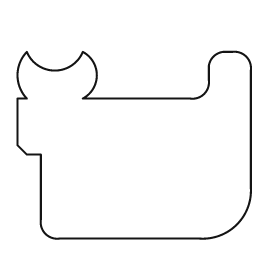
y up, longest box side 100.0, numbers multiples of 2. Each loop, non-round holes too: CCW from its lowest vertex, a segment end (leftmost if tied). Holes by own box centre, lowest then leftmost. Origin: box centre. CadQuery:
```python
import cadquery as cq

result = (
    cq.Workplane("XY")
    .moveTo(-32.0, -40.0)
    .lineTo(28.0, -40.0)
    .threePointArc((44.0, -34.0), (50.0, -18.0))
    .lineTo(50.0, 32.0)
    .threePointArc((48.0, 38.0), (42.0, 40.0))
    .lineTo(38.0, 40.0)
    .threePointArc((34.0, 38.0), (32.0, 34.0))
    .lineTo(32.0, 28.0)
    .threePointArc((30.0, 22.0), (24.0, 20.0))
    .lineTo(-22.0, 20.0)
    .threePointArc((-16.0, 30.0), (-22.0, 40.0))
    .threePointArc((-34.0, 32.0), (-46.0, 40.0))
    .threePointArc((-50.0, 30.0), (-46.0, 20.0))
    .lineTo(-50.0, 20.0)
    .lineTo(-50.0, 0.0)
    .lineTo(-46.0, -4.0)
    .lineTo(-40.0, -4.0)
    .lineTo(-40.0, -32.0)
    .threePointArc((-38.0, -38.0), (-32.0, -40.0))
    .close()
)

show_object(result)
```